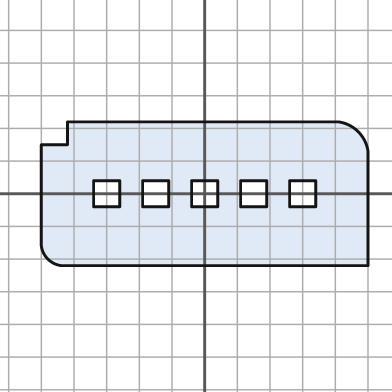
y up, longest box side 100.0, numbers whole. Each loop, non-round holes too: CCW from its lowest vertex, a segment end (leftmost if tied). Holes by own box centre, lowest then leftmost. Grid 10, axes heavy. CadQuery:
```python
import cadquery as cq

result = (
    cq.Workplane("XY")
    .moveTo(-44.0, -22.0)
    .lineTo(50.0, -22.0)
    .lineTo(50.0, 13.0)
    .threePointArc((47.0, 19.0), (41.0, 22.0))
    .lineTo(-42.0, 22.0)
    .lineTo(-42.0, 15.0)
    .lineTo(-50.0, 15.0)
    .lineTo(-50.0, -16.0)
    .threePointArc((-48.0, -20.0), (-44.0, -22.0))
    .close()
    .moveTo(-34.0, -4.0)
    .lineTo(-26.0, -4.0)
    .lineTo(-26.0, 4.0)
    .lineTo(-34.0, 4.0)
    .close()
    .moveTo(-19.0, -4.0)
    .lineTo(-11.0, -4.0)
    .lineTo(-11.0, 4.0)
    .lineTo(-19.0, 4.0)
    .close()
    .moveTo(-4.0, -4.0)
    .lineTo(4.0, -4.0)
    .lineTo(4.0, 4.0)
    .lineTo(-4.0, 4.0)
    .close()
    .moveTo(11.0, -4.0)
    .lineTo(19.0, -4.0)
    .lineTo(19.0, 4.0)
    .lineTo(11.0, 4.0)
    .close()
    .moveTo(26.0, -4.0)
    .lineTo(34.0, -4.0)
    .lineTo(34.0, 4.0)
    .lineTo(26.0, 4.0)
    .close()
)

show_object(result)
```